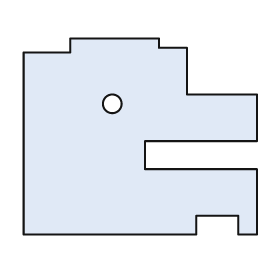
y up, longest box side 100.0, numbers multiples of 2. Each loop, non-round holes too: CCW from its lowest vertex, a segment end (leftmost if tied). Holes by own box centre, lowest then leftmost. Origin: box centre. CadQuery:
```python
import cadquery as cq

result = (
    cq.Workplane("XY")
    .moveTo(-50.0, -42.0)
    .lineTo(24.0, -42.0)
    .lineTo(24.0, -34.0)
    .lineTo(42.0, -34.0)
    .lineTo(42.0, -42.0)
    .lineTo(50.0, -42.0)
    .lineTo(50.0, -14.0)
    .lineTo(2.0, -14.0)
    .lineTo(2.0, -2.0)
    .lineTo(50.0, -2.0)
    .lineTo(50.0, 18.0)
    .lineTo(20.0, 18.0)
    .lineTo(20.0, 38.0)
    .lineTo(8.0, 38.0)
    .lineTo(8.0, 42.0)
    .lineTo(-30.0, 42.0)
    .lineTo(-30.0, 36.0)
    .lineTo(-50.0, 36.0)
    .close()
    .moveTo(-12.0, 14.0)
    .circle(4.0)
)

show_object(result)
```